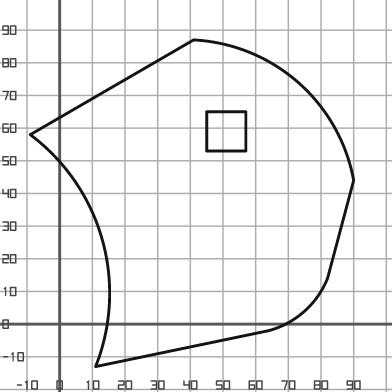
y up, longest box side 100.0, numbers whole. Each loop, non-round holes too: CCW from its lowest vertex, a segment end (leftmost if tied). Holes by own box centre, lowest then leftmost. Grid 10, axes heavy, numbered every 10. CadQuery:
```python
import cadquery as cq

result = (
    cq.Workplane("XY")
    .moveTo(11.0, -13.0)
    .lineTo(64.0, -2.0)
    .threePointArc((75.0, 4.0), (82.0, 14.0))
    .lineTo(90.0, 44.0)
    .threePointArc((73.0, 74.0), (41.0, 87.0))
    .lineTo(-9.0, 58.0)
    .threePointArc((13.0, 26.0), (11.0, -13.0))
    .close()
    .moveTo(45.0, 53.0)
    .lineTo(57.0, 53.0)
    .lineTo(57.0, 65.0)
    .lineTo(45.0, 65.0)
    .close()
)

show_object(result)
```